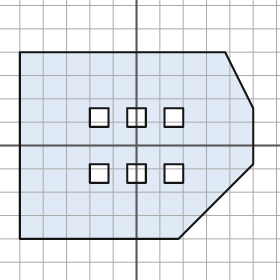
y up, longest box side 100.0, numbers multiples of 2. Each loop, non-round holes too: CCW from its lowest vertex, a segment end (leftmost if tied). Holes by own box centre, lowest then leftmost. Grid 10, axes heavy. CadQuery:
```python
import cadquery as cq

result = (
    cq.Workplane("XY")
    .moveTo(-50.0, -40.0)
    .lineTo(18.0, -40.0)
    .lineTo(50.0, -8.0)
    .lineTo(50.0, 16.0)
    .lineTo(38.0, 40.0)
    .lineTo(-50.0, 40.0)
    .close()
    .moveTo(-20.0, -16.0)
    .lineTo(-12.0, -16.0)
    .lineTo(-12.0, -8.0)
    .lineTo(-20.0, -8.0)
    .close()
    .moveTo(-4.0, -16.0)
    .lineTo(4.0, -16.0)
    .lineTo(4.0, -8.0)
    .lineTo(-4.0, -8.0)
    .close()
    .moveTo(12.0, -16.0)
    .lineTo(20.0, -16.0)
    .lineTo(20.0, -8.0)
    .lineTo(12.0, -8.0)
    .close()
    .moveTo(-20.0, 8.0)
    .lineTo(-12.0, 8.0)
    .lineTo(-12.0, 16.0)
    .lineTo(-20.0, 16.0)
    .close()
    .moveTo(-4.0, 8.0)
    .lineTo(4.0, 8.0)
    .lineTo(4.0, 16.0)
    .lineTo(-4.0, 16.0)
    .close()
    .moveTo(12.0, 8.0)
    .lineTo(20.0, 8.0)
    .lineTo(20.0, 16.0)
    .lineTo(12.0, 16.0)
    .close()
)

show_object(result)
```